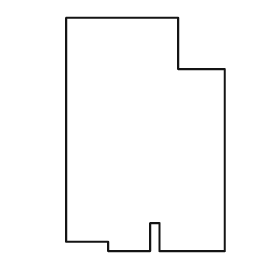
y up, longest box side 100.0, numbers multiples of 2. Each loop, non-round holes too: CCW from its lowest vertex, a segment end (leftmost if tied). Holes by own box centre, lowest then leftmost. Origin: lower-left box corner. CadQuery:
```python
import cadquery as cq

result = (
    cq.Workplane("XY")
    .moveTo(18.0, 0.0)
    .lineTo(36.0, 0.0)
    .lineTo(36.0, 12.0)
    .lineTo(40.0, 12.0)
    .lineTo(40.0, 0.0)
    .lineTo(68.0, 0.0)
    .lineTo(68.0, 78.0)
    .lineTo(48.0, 78.0)
    .lineTo(48.0, 100.0)
    .lineTo(0.0, 100.0)
    .lineTo(0.0, 4.0)
    .lineTo(18.0, 4.0)
    .close()
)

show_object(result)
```